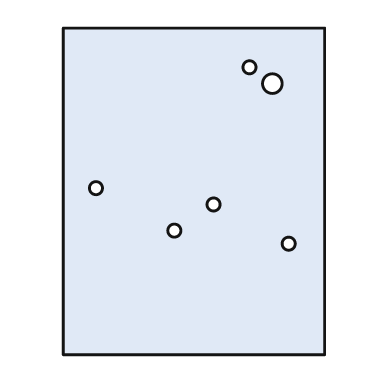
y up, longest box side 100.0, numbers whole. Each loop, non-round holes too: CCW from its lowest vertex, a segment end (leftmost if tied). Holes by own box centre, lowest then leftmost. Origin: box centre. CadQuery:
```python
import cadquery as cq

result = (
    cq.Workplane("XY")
    .moveTo(-40.0, -50.0)
    .lineTo(40.0, -50.0)
    .lineTo(40.0, 50.0)
    .lineTo(-40.0, 50.0)
    .close()
    .moveTo(29.0, -16.0)
    .circle(2.0)
    .moveTo(-6.0, -12.0)
    .circle(2.0)
    .moveTo(6.0, -4.0)
    .circle(2.0)
    .moveTo(-30.0, 1.0)
    .circle(2.0)
    .moveTo(24.0, 33.0)
    .circle(3.0)
    .moveTo(17.0, 38.0)
    .circle(2.0)
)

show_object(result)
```